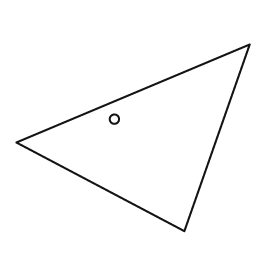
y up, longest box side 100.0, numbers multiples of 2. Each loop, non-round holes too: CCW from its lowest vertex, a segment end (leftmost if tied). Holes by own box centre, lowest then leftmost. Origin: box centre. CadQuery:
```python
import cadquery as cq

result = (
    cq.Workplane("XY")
    .moveTo(22.0, -40.0)
    .lineTo(50.0, 40.0)
    .lineTo(-50.0, -2.0)
    .close()
    .moveTo(-8.0, 8.0)
    .circle(2.0)
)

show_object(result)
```